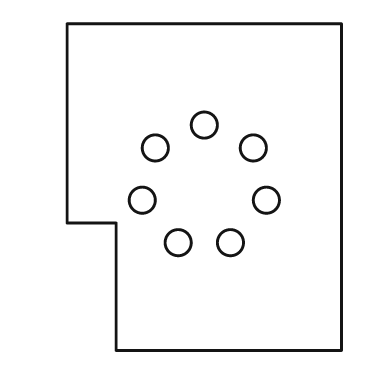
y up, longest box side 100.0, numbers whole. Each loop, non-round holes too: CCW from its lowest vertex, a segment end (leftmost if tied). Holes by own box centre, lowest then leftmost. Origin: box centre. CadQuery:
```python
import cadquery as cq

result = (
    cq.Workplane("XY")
    .moveTo(-27.0, -50.0)
    .lineTo(42.0, -50.0)
    .lineTo(42.0, 50.0)
    .lineTo(-42.0, 50.0)
    .lineTo(-42.0, -11.0)
    .lineTo(-27.0, -11.0)
    .close()
    .moveTo(-8.0, -17.0)
    .circle(4.0)
    .moveTo(8.0, -17.0)
    .circle(4.0)
    .moveTo(-19.0, -4.0)
    .circle(4.0)
    .moveTo(19.0, -4.0)
    .circle(4.0)
    .moveTo(-15.0, 12.0)
    .circle(4.0)
    .moveTo(15.0, 12.0)
    .circle(4.0)
    .moveTo(0.0, 19.0)
    .circle(4.0)
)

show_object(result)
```